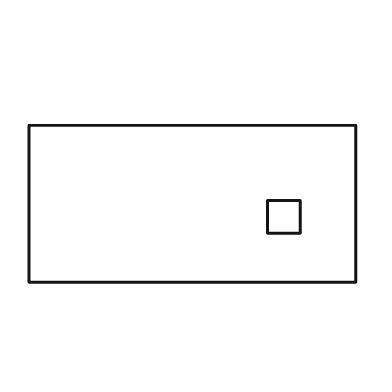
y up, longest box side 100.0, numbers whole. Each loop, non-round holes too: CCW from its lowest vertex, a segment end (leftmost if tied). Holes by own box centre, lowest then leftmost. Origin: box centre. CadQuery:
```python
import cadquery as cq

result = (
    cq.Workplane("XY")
    .moveTo(-50.0, -24.0)
    .lineTo(50.0, -24.0)
    .lineTo(50.0, 24.0)
    .lineTo(-50.0, 24.0)
    .close()
    .moveTo(23.0, -9.0)
    .lineTo(33.0, -9.0)
    .lineTo(33.0, 1.0)
    .lineTo(23.0, 1.0)
    .close()
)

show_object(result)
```